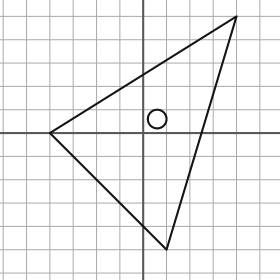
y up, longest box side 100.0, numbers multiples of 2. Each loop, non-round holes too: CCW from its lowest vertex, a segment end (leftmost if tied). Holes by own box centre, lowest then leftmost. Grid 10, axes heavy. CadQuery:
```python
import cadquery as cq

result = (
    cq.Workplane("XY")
    .moveTo(10.0, -50.0)
    .lineTo(40.0, 50.0)
    .lineTo(-40.0, 0.0)
    .close()
    .moveTo(6.0, 6.0)
    .circle(4.0)
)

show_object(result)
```